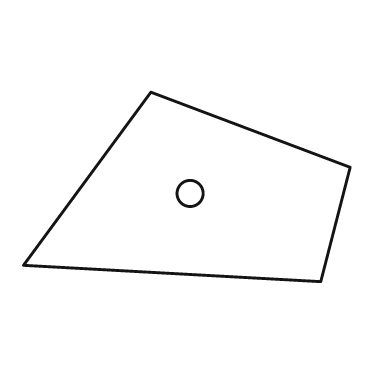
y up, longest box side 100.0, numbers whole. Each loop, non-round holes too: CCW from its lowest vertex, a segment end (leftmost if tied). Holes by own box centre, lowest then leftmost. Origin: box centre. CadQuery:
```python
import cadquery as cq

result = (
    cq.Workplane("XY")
    .moveTo(41.0, -29.0)
    .lineTo(50.0, 6.0)
    .lineTo(-11.0, 29.0)
    .lineTo(-50.0, -24.0)
    .close()
    .moveTo(1.0, -2.0)
    .circle(4.0)
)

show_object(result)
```